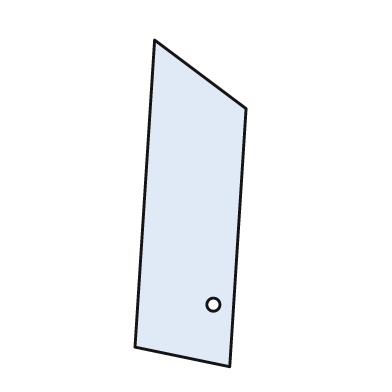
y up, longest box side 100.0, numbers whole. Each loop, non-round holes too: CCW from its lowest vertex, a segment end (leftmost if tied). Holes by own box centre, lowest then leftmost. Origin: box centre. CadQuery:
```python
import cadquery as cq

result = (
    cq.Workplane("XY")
    .moveTo(12.0, -50.0)
    .lineTo(17.0, 29.0)
    .lineTo(-11.0, 50.0)
    .lineTo(-17.0, -44.0)
    .close()
    .moveTo(7.0, -31.0)
    .circle(2.0)
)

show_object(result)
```